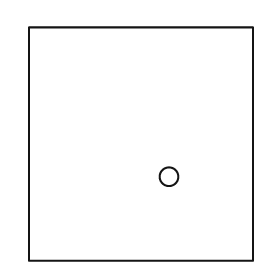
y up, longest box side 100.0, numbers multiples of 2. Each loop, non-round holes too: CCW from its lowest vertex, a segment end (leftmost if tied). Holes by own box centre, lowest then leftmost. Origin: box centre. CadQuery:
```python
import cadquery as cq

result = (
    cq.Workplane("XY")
    .moveTo(-48.0, -50.0)
    .lineTo(48.0, -50.0)
    .lineTo(48.0, 50.0)
    .lineTo(-48.0, 50.0)
    .close()
    .moveTo(12.0, -14.0)
    .circle(4.0)
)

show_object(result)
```